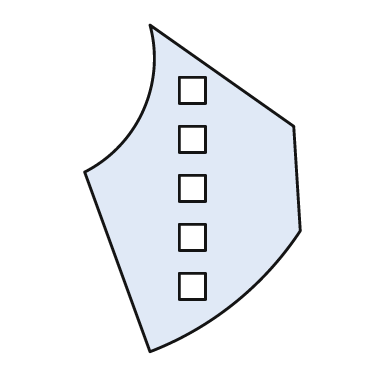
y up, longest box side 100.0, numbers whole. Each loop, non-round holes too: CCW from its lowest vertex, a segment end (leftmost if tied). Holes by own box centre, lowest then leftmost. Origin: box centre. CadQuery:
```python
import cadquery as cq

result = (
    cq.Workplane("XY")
    .moveTo(-13.0, -50.0)
    .threePointArc((13.0, -35.0), (33.0, -13.0))
    .lineTo(31.0, 19.0)
    .lineTo(-13.0, 50.0)
    .threePointArc((-15.0, 24.0), (-33.0, 5.0))
    .close()
    .moveTo(-4.0, -34.0)
    .lineTo(4.0, -34.0)
    .lineTo(4.0, -26.0)
    .lineTo(-4.0, -26.0)
    .close()
    .moveTo(-4.0, -19.0)
    .lineTo(4.0, -19.0)
    .lineTo(4.0, -11.0)
    .lineTo(-4.0, -11.0)
    .close()
    .moveTo(-4.0, -4.0)
    .lineTo(4.0, -4.0)
    .lineTo(4.0, 4.0)
    .lineTo(-4.0, 4.0)
    .close()
    .moveTo(-4.0, 11.0)
    .lineTo(4.0, 11.0)
    .lineTo(4.0, 19.0)
    .lineTo(-4.0, 19.0)
    .close()
    .moveTo(-4.0, 26.0)
    .lineTo(4.0, 26.0)
    .lineTo(4.0, 34.0)
    .lineTo(-4.0, 34.0)
    .close()
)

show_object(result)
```